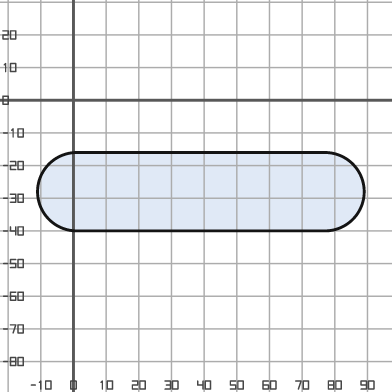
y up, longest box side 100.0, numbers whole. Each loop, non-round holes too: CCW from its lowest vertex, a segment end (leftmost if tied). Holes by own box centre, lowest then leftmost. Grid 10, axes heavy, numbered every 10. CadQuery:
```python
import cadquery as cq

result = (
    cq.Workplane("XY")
    .moveTo(1.0, -40.0)
    .lineTo(77.0, -40.0)
    .threePointArc((89.0, -28.0), (77.0, -16.0))
    .lineTo(1.0, -16.0)
    .threePointArc((-11.0, -28.0), (1.0, -40.0))
    .close()
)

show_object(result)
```